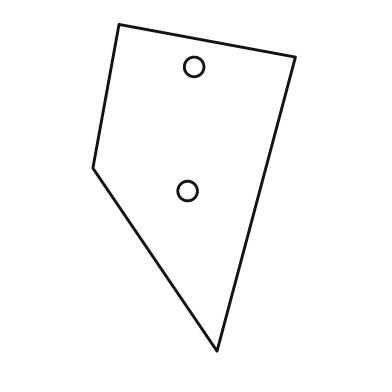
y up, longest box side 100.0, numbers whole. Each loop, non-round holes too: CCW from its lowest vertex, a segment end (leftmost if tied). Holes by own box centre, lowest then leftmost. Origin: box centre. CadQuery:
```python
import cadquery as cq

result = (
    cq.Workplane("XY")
    .moveTo(7.0, -50.0)
    .lineTo(31.0, 40.0)
    .lineTo(-23.0, 50.0)
    .lineTo(-31.0, 6.0)
    .close()
    .moveTo(-2.0, -1.0)
    .circle(3.0)
    .moveTo(0.0, 37.0)
    .circle(3.0)
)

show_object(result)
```